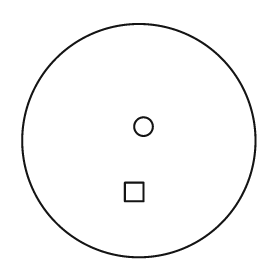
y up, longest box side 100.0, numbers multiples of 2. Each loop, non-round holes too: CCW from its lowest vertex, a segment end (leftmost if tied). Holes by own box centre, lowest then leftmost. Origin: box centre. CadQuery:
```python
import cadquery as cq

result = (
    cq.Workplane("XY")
    .moveTo(0.0, 0.0)
    .circle(50.0)
    .moveTo(-6.0, -26.0)
    .lineTo(2.0, -26.0)
    .lineTo(2.0, -18.0)
    .lineTo(-6.0, -18.0)
    .close()
    .moveTo(2.0, 6.0)
    .circle(4.0)
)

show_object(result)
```